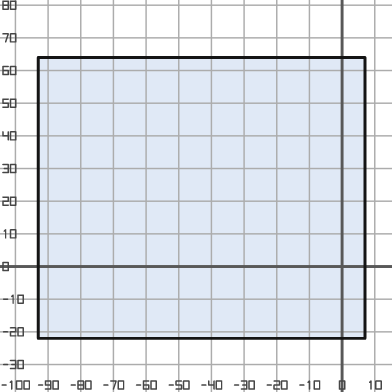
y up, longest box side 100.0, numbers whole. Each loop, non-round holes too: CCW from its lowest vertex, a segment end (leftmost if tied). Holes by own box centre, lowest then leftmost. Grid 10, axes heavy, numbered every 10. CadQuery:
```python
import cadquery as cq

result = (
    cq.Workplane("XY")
    .moveTo(-93.0, -22.0)
    .lineTo(7.0, -22.0)
    .lineTo(7.0, 64.0)
    .lineTo(-93.0, 64.0)
    .close()
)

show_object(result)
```